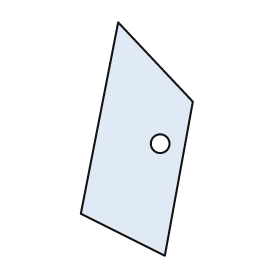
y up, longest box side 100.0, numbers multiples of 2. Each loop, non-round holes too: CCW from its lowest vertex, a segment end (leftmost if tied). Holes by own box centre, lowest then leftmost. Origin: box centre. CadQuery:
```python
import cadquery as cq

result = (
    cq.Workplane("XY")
    .moveTo(12.0, -50.0)
    .lineTo(24.0, 16.0)
    .lineTo(-8.0, 50.0)
    .lineTo(-24.0, -32.0)
    .close()
    .moveTo(10.0, -2.0)
    .circle(4.0)
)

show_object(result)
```